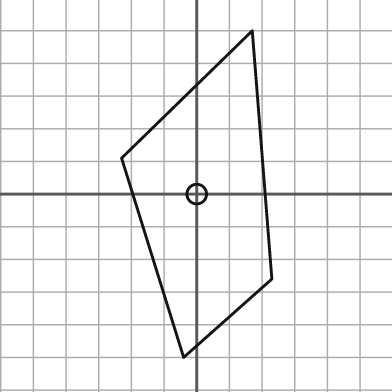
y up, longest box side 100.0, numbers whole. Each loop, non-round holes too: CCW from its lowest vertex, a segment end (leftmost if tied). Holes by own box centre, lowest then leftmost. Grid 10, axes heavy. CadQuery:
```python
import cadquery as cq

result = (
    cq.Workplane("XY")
    .moveTo(-4.0, -50.0)
    .lineTo(23.0, -26.0)
    .lineTo(17.0, 50.0)
    .lineTo(-23.0, 11.0)
    .close()
    .moveTo(0.0, 0.0)
    .circle(3.0)
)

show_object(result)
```